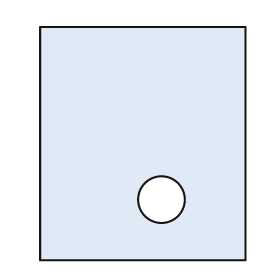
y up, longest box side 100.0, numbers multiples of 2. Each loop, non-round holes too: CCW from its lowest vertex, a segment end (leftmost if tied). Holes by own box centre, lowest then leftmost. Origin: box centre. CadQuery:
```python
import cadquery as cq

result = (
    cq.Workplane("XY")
    .moveTo(-44.0, -50.0)
    .lineTo(44.0, -50.0)
    .lineTo(44.0, 50.0)
    .lineTo(-44.0, 50.0)
    .close()
    .moveTo(8.0, -24.0)
    .circle(10.0)
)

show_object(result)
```